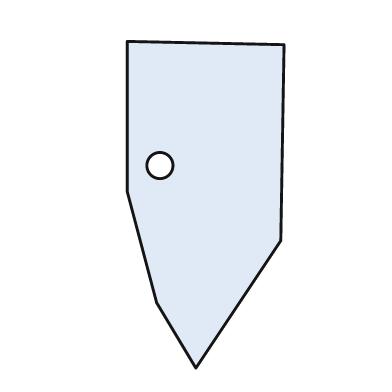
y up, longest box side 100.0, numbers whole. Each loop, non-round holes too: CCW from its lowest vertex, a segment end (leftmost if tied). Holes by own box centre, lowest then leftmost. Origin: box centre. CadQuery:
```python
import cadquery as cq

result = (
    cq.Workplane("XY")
    .moveTo(-3.0, -50.0)
    .lineTo(23.0, -11.0)
    .lineTo(24.0, 49.0)
    .lineTo(-24.0, 50.0)
    .lineTo(-24.0, 4.0)
    .lineTo(-15.0, -30.0)
    .close()
    .moveTo(-14.0, 12.0)
    .circle(4.0)
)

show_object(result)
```